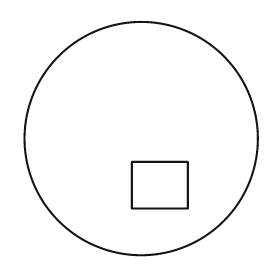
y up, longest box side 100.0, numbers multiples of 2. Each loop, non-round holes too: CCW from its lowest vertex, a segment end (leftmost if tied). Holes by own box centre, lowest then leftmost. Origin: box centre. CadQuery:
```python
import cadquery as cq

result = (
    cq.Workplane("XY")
    .moveTo(0.0, 0.0)
    .circle(50.0)
    .moveTo(-4.0, -30.0)
    .lineTo(20.0, -30.0)
    .lineTo(20.0, -10.0)
    .lineTo(-4.0, -10.0)
    .close()
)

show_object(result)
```